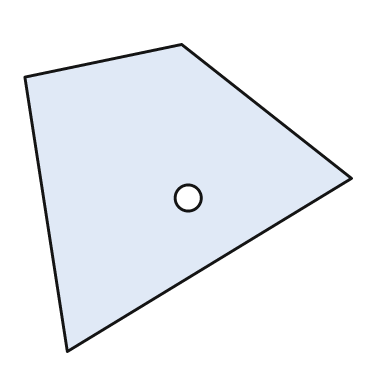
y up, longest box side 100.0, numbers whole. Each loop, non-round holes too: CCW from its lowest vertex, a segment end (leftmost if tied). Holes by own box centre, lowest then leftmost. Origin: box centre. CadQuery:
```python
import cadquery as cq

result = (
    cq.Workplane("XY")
    .moveTo(-37.0, -47.0)
    .lineTo(50.0, 6.0)
    .lineTo(-2.0, 47.0)
    .lineTo(-50.0, 37.0)
    .close()
    .moveTo(0.0, 0.0)
    .circle(4.0)
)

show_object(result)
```